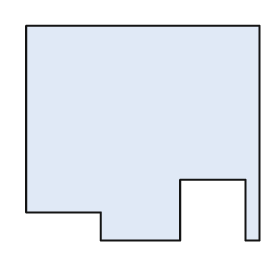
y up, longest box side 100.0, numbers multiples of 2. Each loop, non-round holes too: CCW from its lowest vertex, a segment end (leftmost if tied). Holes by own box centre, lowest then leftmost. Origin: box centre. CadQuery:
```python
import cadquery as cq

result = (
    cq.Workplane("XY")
    .moveTo(-18.0, -46.0)
    .lineTo(16.0, -46.0)
    .lineTo(16.0, -20.0)
    .lineTo(44.0, -20.0)
    .lineTo(44.0, -46.0)
    .lineTo(50.0, -46.0)
    .lineTo(50.0, 46.0)
    .lineTo(-50.0, 46.0)
    .lineTo(-50.0, -34.0)
    .lineTo(-18.0, -34.0)
    .close()
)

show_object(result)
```